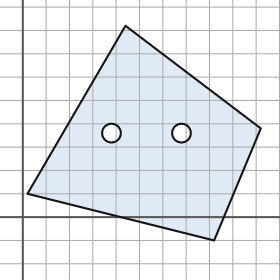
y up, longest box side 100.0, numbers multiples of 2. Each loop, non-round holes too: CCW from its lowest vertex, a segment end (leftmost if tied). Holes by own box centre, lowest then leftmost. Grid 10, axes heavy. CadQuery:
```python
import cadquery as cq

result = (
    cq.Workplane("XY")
    .moveTo(82.0, -10.0)
    .lineTo(102.0, 38.0)
    .lineTo(44.0, 82.0)
    .lineTo(2.0, 10.0)
    .close()
    .moveTo(38.0, 36.0)
    .circle(4.0)
    .moveTo(68.0, 36.0)
    .circle(4.0)
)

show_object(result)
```